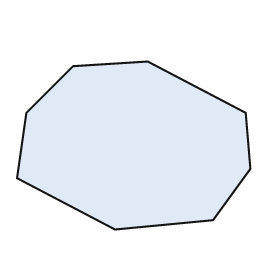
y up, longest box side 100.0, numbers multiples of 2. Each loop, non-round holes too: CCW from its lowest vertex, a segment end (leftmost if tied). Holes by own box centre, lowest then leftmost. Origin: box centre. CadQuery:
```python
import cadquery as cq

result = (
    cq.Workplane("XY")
    .moveTo(-8.0, -36.0)
    .lineTo(34.0, -32.0)
    .lineTo(50.0, -10.0)
    .lineTo(48.0, 14.0)
    .lineTo(6.0, 36.0)
    .lineTo(-26.0, 34.0)
    .lineTo(-46.0, 14.0)
    .lineTo(-50.0, -14.0)
    .close()
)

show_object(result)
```